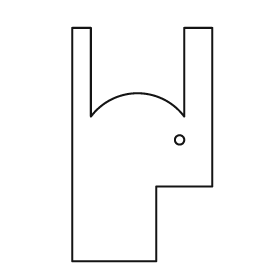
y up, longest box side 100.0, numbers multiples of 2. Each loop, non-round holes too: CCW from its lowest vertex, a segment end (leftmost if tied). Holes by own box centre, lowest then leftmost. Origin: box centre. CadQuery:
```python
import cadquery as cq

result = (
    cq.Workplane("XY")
    .moveTo(-30.0, -50.0)
    .lineTo(6.0, -50.0)
    .lineTo(6.0, -18.0)
    .lineTo(30.0, -18.0)
    .lineTo(30.0, 50.0)
    .lineTo(18.0, 50.0)
    .lineTo(18.0, 12.0)
    .threePointArc((-2.0, 22.0), (-22.0, 12.0))
    .lineTo(-22.0, 50.0)
    .lineTo(-30.0, 50.0)
    .close()
    .moveTo(16.0, 2.0)
    .circle(2.0)
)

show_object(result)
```